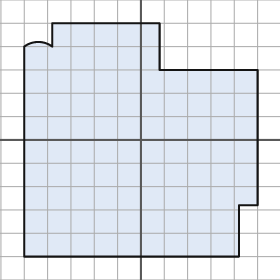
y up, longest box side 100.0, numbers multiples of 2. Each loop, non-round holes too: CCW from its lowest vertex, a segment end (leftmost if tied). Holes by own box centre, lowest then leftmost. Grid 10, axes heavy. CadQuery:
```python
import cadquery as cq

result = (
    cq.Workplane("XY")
    .moveTo(-50.0, -50.0)
    .lineTo(42.0, -50.0)
    .lineTo(42.0, -28.0)
    .lineTo(50.0, -28.0)
    .lineTo(50.0, 30.0)
    .lineTo(8.0, 30.0)
    .lineTo(8.0, 50.0)
    .lineTo(-38.0, 50.0)
    .lineTo(-38.0, 40.0)
    .threePointArc((-44.0, 42.0), (-50.0, 40.0))
    .close()
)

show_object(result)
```